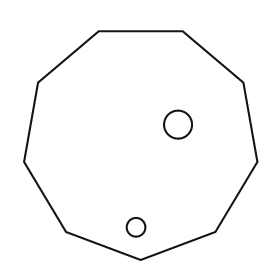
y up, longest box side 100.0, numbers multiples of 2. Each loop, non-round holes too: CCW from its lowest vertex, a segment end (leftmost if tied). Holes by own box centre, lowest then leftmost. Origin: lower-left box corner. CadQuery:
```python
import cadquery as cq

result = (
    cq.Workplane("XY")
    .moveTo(50.0, 0.0)
    .lineTo(82.0, 12.0)
    .lineTo(100.0, 42.0)
    .lineTo(94.0, 76.0)
    .lineTo(68.0, 98.0)
    .lineTo(32.0, 98.0)
    .lineTo(6.0, 76.0)
    .lineTo(0.0, 42.0)
    .lineTo(18.0, 12.0)
    .close()
    .moveTo(48.0, 14.0)
    .circle(4.0)
    .moveTo(66.0, 58.0)
    .circle(6.0)
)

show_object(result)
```